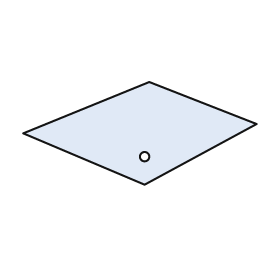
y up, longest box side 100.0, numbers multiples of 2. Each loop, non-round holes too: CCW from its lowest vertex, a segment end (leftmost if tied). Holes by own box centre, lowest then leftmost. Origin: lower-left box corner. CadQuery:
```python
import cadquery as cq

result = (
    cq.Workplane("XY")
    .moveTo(52.0, 0.0)
    .lineTo(100.0, 26.0)
    .lineTo(54.0, 44.0)
    .lineTo(0.0, 22.0)
    .close()
    .moveTo(52.0, 12.0)
    .circle(2.0)
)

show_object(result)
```